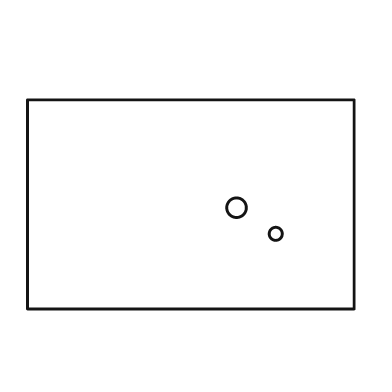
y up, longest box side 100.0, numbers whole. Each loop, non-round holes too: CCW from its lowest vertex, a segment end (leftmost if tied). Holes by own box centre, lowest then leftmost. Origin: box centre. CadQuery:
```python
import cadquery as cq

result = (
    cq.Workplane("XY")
    .moveTo(-50.0, -32.0)
    .lineTo(50.0, -32.0)
    .lineTo(50.0, 32.0)
    .lineTo(-50.0, 32.0)
    .close()
    .moveTo(26.0, -9.0)
    .circle(2.0)
    .moveTo(14.0, -1.0)
    .circle(3.0)
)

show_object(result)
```